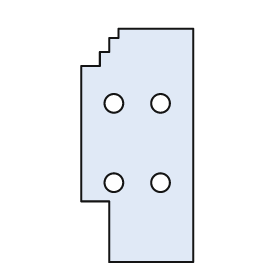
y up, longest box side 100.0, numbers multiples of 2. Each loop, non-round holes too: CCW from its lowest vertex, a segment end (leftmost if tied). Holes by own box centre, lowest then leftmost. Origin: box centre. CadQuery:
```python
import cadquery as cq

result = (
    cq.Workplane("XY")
    .moveTo(-12.0, -50.0)
    .lineTo(24.0, -50.0)
    .lineTo(24.0, 50.0)
    .lineTo(-8.0, 50.0)
    .lineTo(-8.0, 46.0)
    .lineTo(-12.0, 46.0)
    .lineTo(-12.0, 40.0)
    .lineTo(-16.0, 40.0)
    .lineTo(-16.0, 34.0)
    .lineTo(-24.0, 34.0)
    .lineTo(-24.0, -24.0)
    .lineTo(-12.0, -24.0)
    .close()
    .moveTo(-10.0, -16.0)
    .circle(4.0)
    .moveTo(10.0, -16.0)
    .circle(4.0)
    .moveTo(-10.0, 18.0)
    .circle(4.0)
    .moveTo(10.0, 18.0)
    .circle(4.0)
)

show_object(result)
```